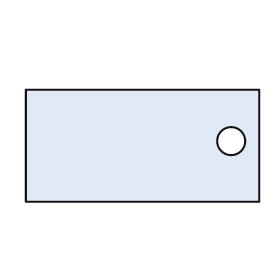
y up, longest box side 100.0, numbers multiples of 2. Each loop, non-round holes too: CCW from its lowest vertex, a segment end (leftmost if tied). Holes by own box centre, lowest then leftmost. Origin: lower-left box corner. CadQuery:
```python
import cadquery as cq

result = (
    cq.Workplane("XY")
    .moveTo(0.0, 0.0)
    .lineTo(100.0, 0.0)
    .lineTo(100.0, 48.0)
    .lineTo(0.0, 48.0)
    .close()
    .moveTo(88.0, 26.0)
    .circle(6.0)
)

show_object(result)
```